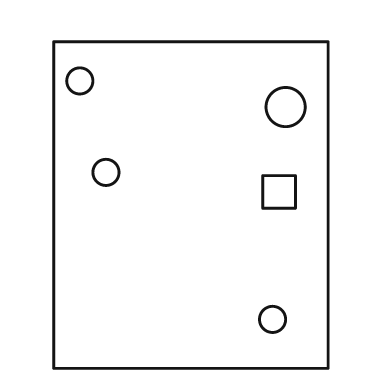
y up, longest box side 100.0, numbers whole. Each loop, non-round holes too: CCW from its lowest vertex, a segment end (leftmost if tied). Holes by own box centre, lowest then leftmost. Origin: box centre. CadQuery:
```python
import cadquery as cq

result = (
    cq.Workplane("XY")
    .moveTo(-42.0, -50.0)
    .lineTo(42.0, -50.0)
    .lineTo(42.0, 50.0)
    .lineTo(-42.0, 50.0)
    .close()
    .moveTo(25.0, -35.0)
    .circle(4.0)
    .moveTo(22.0, -1.0)
    .lineTo(32.0, -1.0)
    .lineTo(32.0, 9.0)
    .lineTo(22.0, 9.0)
    .close()
    .moveTo(-26.0, 10.0)
    .circle(4.0)
    .moveTo(29.0, 30.0)
    .circle(6.0)
    .moveTo(-34.0, 38.0)
    .circle(4.0)
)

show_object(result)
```